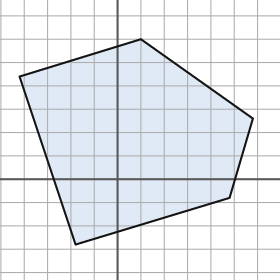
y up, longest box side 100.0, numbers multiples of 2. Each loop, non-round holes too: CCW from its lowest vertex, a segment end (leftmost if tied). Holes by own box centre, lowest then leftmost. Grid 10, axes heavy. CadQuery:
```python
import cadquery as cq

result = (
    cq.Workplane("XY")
    .moveTo(-18.0, -28.0)
    .lineTo(48.0, -8.0)
    .lineTo(58.0, 26.0)
    .lineTo(10.0, 60.0)
    .lineTo(-42.0, 44.0)
    .close()
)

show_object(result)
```